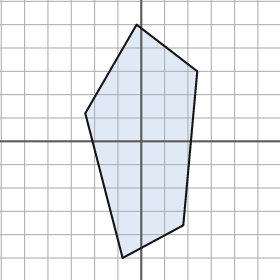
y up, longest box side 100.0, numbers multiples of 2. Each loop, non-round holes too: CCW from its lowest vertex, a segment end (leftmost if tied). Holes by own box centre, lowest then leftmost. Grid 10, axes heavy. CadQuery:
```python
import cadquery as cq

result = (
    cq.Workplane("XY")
    .moveTo(-8.0, -50.0)
    .lineTo(18.0, -36.0)
    .lineTo(24.0, 30.0)
    .lineTo(-2.0, 50.0)
    .lineTo(-24.0, 12.0)
    .close()
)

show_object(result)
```